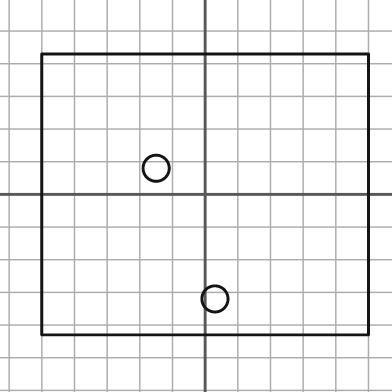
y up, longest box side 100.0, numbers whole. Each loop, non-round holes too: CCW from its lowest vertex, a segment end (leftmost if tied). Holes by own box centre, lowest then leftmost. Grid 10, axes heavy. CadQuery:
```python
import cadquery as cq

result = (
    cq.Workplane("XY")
    .moveTo(-50.0, -43.0)
    .lineTo(50.0, -43.0)
    .lineTo(50.0, 43.0)
    .lineTo(-50.0, 43.0)
    .close()
    .moveTo(3.0, -32.0)
    .circle(4.0)
    .moveTo(-15.0, 8.0)
    .circle(4.0)
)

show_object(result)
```